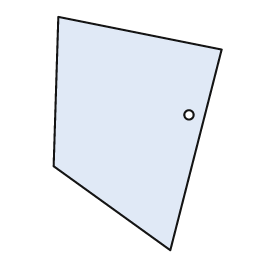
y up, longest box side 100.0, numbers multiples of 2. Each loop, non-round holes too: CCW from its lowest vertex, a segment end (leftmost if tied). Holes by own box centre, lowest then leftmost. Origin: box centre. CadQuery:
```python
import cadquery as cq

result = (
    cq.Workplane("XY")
    .moveTo(14.0, -50.0)
    .lineTo(36.0, 36.0)
    .lineTo(-34.0, 50.0)
    .lineTo(-36.0, -14.0)
    .close()
    .moveTo(22.0, 8.0)
    .circle(2.0)
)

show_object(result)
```